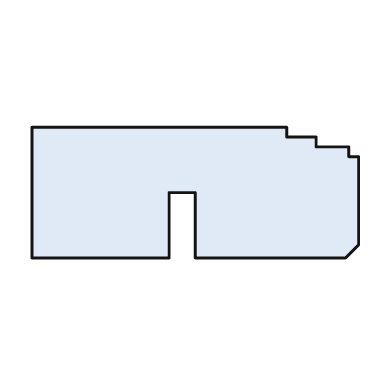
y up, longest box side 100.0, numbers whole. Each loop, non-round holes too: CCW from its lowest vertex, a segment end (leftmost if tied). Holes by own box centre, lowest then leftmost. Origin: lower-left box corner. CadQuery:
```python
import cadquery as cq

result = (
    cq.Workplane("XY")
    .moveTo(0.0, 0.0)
    .lineTo(42.0, 0.0)
    .lineTo(42.0, 20.0)
    .lineTo(50.0, 20.0)
    .lineTo(50.0, 0.0)
    .lineTo(96.0, 0.0)
    .lineTo(100.0, 4.0)
    .lineTo(100.0, 31.0)
    .lineTo(97.0, 31.0)
    .lineTo(97.0, 34.0)
    .lineTo(87.0, 34.0)
    .lineTo(87.0, 37.0)
    .lineTo(78.0, 37.0)
    .lineTo(78.0, 40.0)
    .lineTo(0.0, 40.0)
    .close()
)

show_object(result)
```